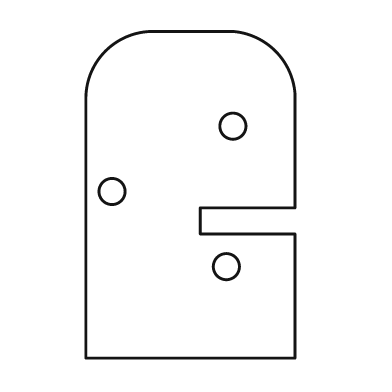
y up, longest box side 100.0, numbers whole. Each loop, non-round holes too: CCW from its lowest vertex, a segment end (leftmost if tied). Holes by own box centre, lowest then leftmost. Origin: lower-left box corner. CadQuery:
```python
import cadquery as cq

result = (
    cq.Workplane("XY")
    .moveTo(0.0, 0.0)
    .lineTo(64.0, 0.0)
    .lineTo(64.0, 38.0)
    .lineTo(35.0, 38.0)
    .lineTo(35.0, 46.0)
    .lineTo(64.0, 46.0)
    .lineTo(64.0, 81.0)
    .threePointArc((58.0, 94.0), (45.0, 100.0))
    .lineTo(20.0, 100.0)
    .threePointArc((6.0, 94.0), (0.0, 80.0))
    .close()
    .moveTo(43.0, 28.0)
    .circle(4.0)
    .moveTo(8.0, 51.0)
    .circle(4.0)
    .moveTo(45.0, 71.0)
    .circle(4.0)
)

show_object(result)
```